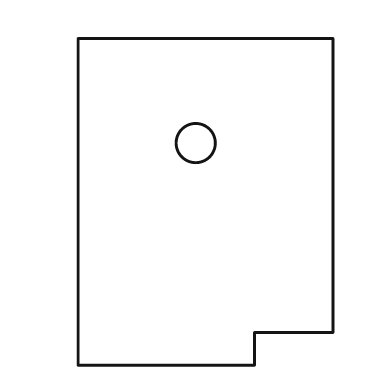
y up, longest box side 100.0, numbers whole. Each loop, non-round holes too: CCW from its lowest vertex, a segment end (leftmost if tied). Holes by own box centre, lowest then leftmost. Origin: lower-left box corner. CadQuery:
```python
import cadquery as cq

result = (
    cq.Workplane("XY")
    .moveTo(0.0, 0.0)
    .lineTo(54.0, 0.0)
    .lineTo(54.0, 10.0)
    .lineTo(78.0, 10.0)
    .lineTo(78.0, 100.0)
    .lineTo(0.0, 100.0)
    .close()
    .moveTo(36.0, 68.0)
    .circle(6.0)
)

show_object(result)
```